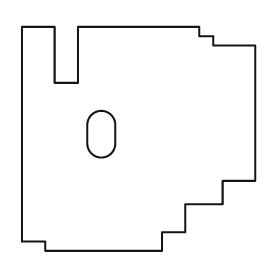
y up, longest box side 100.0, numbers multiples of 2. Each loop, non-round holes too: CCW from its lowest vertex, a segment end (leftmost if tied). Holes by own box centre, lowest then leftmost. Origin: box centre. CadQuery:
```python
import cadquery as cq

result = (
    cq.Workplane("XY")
    .moveTo(-40.0, -48.0)
    .lineTo(10.0, -48.0)
    .lineTo(10.0, -40.0)
    .lineTo(20.0, -40.0)
    .lineTo(20.0, -28.0)
    .lineTo(36.0, -28.0)
    .lineTo(36.0, -18.0)
    .lineTo(50.0, -18.0)
    .lineTo(50.0, 40.0)
    .lineTo(32.0, 40.0)
    .lineTo(32.0, 44.0)
    .lineTo(26.0, 44.0)
    .lineTo(26.0, 48.0)
    .lineTo(-26.0, 48.0)
    .lineTo(-26.0, 24.0)
    .lineTo(-36.0, 24.0)
    .lineTo(-36.0, 48.0)
    .lineTo(-50.0, 48.0)
    .lineTo(-50.0, -44.0)
    .lineTo(-40.0, -44.0)
    .close()
    .moveTo(-22.0, -2.0)
    .threePointArc((-16.0, -8.0), (-10.0, -2.0))
    .lineTo(-10.0, 6.0)
    .threePointArc((-16.0, 12.0), (-22.0, 6.0))
    .close()
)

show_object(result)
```